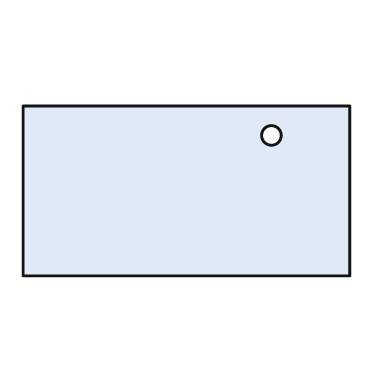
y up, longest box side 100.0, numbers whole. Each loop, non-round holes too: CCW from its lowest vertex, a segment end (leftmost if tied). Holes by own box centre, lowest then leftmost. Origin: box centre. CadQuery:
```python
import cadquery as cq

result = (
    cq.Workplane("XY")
    .moveTo(-50.0, -26.0)
    .lineTo(50.0, -26.0)
    .lineTo(50.0, 26.0)
    .lineTo(-50.0, 26.0)
    .close()
    .moveTo(26.0, 17.0)
    .circle(3.0)
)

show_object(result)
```